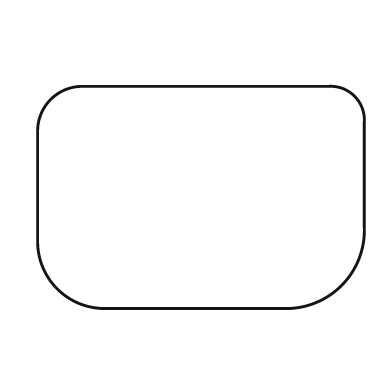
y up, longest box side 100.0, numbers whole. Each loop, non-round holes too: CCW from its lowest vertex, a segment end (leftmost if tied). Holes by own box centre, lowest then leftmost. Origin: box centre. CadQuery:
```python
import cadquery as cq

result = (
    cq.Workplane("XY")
    .moveTo(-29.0, -34.0)
    .lineTo(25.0, -34.0)
    .threePointArc((43.0, -27.0), (50.0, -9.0))
    .lineTo(50.0, 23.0)
    .threePointArc((47.0, 31.0), (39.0, 34.0))
    .lineTo(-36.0, 34.0)
    .threePointArc((-46.0, 30.0), (-50.0, 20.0))
    .lineTo(-50.0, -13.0)
    .threePointArc((-44.0, -28.0), (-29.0, -34.0))
    .close()
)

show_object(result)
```